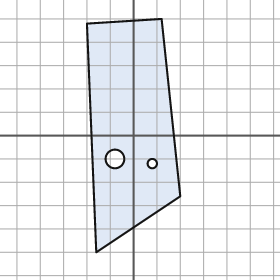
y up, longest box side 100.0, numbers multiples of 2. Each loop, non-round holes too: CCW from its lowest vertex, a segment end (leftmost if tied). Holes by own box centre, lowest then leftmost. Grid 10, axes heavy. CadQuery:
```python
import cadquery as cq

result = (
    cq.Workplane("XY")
    .moveTo(-16.0, -50.0)
    .lineTo(20.0, -26.0)
    .lineTo(12.0, 50.0)
    .lineTo(-20.0, 48.0)
    .close()
    .moveTo(8.0, -12.0)
    .circle(2.0)
    .moveTo(-8.0, -10.0)
    .circle(4.0)
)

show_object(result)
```